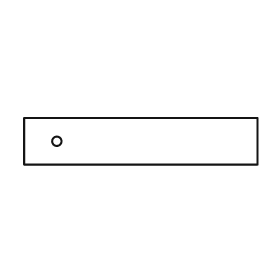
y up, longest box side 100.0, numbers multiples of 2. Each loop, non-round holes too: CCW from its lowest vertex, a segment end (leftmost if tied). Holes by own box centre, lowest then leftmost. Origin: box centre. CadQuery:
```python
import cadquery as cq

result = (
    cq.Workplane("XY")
    .moveTo(-50.0, -10.0)
    .lineTo(50.0, -10.0)
    .lineTo(50.0, 10.0)
    .lineTo(-50.0, 10.0)
    .close()
    .moveTo(-36.0, 0.0)
    .circle(2.0)
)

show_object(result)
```